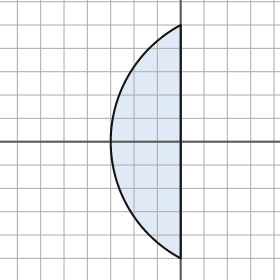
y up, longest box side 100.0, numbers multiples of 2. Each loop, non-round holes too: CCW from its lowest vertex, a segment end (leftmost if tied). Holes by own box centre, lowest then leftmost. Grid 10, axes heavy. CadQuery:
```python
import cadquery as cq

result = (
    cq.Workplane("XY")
    .moveTo(0.0, -50.0)
    .lineTo(0.0, 50.0)
    .threePointArc((-30.0, 0.0), (0.0, -50.0))
    .close()
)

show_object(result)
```